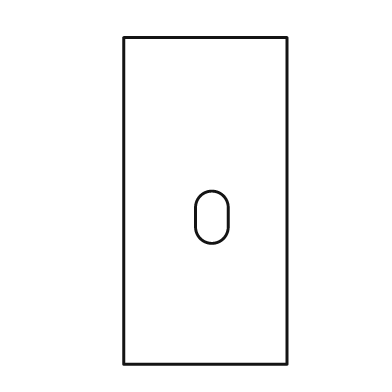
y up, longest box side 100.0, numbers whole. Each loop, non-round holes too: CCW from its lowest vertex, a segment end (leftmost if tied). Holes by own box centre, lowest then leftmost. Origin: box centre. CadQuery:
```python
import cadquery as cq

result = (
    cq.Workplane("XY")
    .moveTo(-25.0, -50.0)
    .lineTo(25.0, -50.0)
    .lineTo(25.0, 50.0)
    .lineTo(-25.0, 50.0)
    .close()
    .moveTo(-3.0, -8.0)
    .threePointArc((2.0, -13.0), (7.0, -8.0))
    .lineTo(7.0, -2.0)
    .threePointArc((2.0, 3.0), (-3.0, -2.0))
    .close()
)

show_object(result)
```